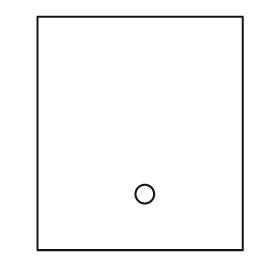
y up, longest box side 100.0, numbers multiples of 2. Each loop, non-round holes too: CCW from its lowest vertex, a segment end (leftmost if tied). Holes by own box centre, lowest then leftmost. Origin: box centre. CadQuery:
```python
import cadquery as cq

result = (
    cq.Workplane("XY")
    .moveTo(-44.0, -50.0)
    .lineTo(44.0, -50.0)
    .lineTo(44.0, 50.0)
    .lineTo(-44.0, 50.0)
    .close()
    .moveTo(2.0, -26.0)
    .circle(4.0)
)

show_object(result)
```